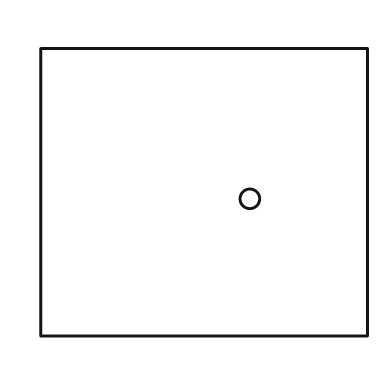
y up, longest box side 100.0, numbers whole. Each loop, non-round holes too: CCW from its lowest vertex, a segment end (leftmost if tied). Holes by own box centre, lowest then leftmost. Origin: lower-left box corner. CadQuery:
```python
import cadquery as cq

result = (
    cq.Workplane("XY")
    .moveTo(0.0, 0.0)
    .lineTo(100.0, 0.0)
    .lineTo(100.0, 88.0)
    .lineTo(0.0, 88.0)
    .close()
    .moveTo(64.0, 42.0)
    .circle(3.0)
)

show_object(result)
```